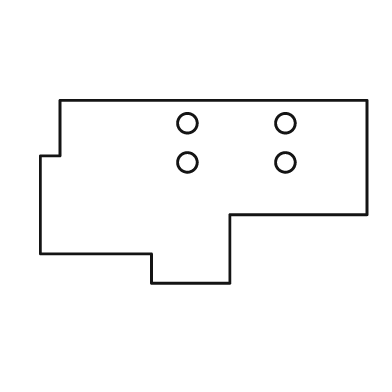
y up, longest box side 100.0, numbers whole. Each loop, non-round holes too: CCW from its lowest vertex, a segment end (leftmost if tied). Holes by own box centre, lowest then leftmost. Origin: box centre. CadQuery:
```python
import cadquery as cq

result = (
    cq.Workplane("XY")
    .moveTo(-16.0, -28.0)
    .lineTo(8.0, -28.0)
    .lineTo(8.0, -7.0)
    .lineTo(50.0, -7.0)
    .lineTo(50.0, 28.0)
    .lineTo(-44.0, 28.0)
    .lineTo(-44.0, 11.0)
    .lineTo(-50.0, 11.0)
    .lineTo(-50.0, -19.0)
    .lineTo(-16.0, -19.0)
    .close()
    .moveTo(-5.0, 9.0)
    .circle(3.0)
    .moveTo(25.0, 9.0)
    .circle(3.0)
    .moveTo(-5.0, 21.0)
    .circle(3.0)
    .moveTo(25.0, 21.0)
    .circle(3.0)
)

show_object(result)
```